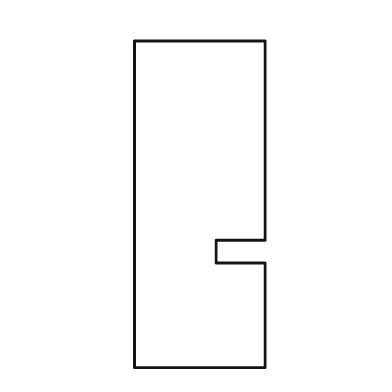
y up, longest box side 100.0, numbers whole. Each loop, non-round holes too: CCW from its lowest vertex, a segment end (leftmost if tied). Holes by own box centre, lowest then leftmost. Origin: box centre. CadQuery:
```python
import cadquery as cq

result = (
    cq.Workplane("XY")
    .moveTo(-20.0, -50.0)
    .lineTo(20.0, -50.0)
    .lineTo(20.0, -18.0)
    .lineTo(5.0, -18.0)
    .lineTo(5.0, -11.0)
    .lineTo(20.0, -11.0)
    .lineTo(20.0, 50.0)
    .lineTo(-20.0, 50.0)
    .close()
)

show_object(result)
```